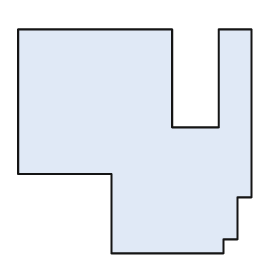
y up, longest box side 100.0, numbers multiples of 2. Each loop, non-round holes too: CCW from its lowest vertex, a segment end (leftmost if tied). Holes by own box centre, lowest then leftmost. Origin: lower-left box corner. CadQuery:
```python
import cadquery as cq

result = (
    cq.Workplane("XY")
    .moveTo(40.0, 0.0)
    .lineTo(88.0, 0.0)
    .lineTo(88.0, 6.0)
    .lineTo(94.0, 6.0)
    .lineTo(94.0, 24.0)
    .lineTo(100.0, 24.0)
    .lineTo(100.0, 96.0)
    .lineTo(86.0, 96.0)
    .lineTo(86.0, 54.0)
    .lineTo(66.0, 54.0)
    .lineTo(66.0, 96.0)
    .lineTo(0.0, 96.0)
    .lineTo(0.0, 34.0)
    .lineTo(40.0, 34.0)
    .close()
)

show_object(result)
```